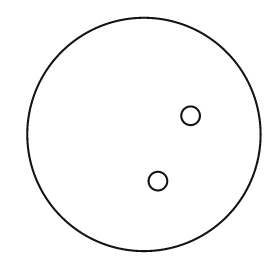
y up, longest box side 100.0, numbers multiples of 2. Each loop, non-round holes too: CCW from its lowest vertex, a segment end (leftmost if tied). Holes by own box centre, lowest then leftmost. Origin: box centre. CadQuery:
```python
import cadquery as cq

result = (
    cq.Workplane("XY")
    .moveTo(0.0, 0.0)
    .circle(50.0)
    .moveTo(6.0, -20.0)
    .circle(4.0)
    .moveTo(20.0, 8.0)
    .circle(4.0)
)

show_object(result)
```